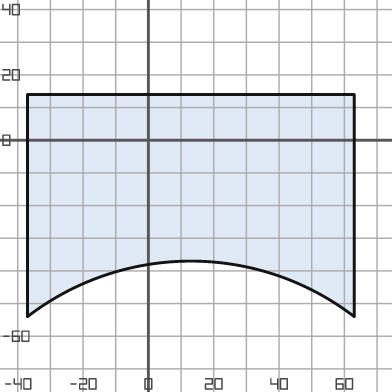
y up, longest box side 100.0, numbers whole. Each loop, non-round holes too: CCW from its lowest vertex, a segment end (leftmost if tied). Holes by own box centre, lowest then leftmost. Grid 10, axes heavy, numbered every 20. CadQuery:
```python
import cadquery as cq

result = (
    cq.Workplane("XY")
    .moveTo(-37.0, -54.0)
    .threePointArc((13.0, -37.0), (63.0, -54.0))
    .lineTo(63.0, 14.0)
    .lineTo(-37.0, 14.0)
    .close()
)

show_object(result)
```